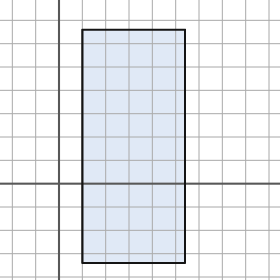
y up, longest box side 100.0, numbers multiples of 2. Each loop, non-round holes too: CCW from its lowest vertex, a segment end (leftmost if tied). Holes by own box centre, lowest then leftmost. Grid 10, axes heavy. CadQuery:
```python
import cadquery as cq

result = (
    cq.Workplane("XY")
    .moveTo(10.0, -34.0)
    .lineTo(54.0, -34.0)
    .lineTo(54.0, 66.0)
    .lineTo(10.0, 66.0)
    .close()
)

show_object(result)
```